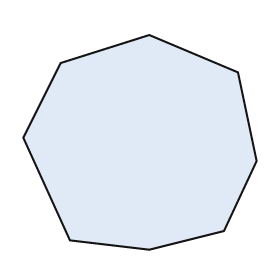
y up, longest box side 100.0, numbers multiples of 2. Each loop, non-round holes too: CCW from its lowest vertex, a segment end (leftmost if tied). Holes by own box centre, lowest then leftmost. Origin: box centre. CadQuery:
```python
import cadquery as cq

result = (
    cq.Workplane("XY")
    .moveTo(4.0, -46.0)
    .lineTo(36.0, -38.0)
    .lineTo(50.0, -8.0)
    .lineTo(42.0, 30.0)
    .lineTo(4.0, 46.0)
    .lineTo(-34.0, 34.0)
    .lineTo(-50.0, 2.0)
    .lineTo(-30.0, -42.0)
    .close()
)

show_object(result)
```